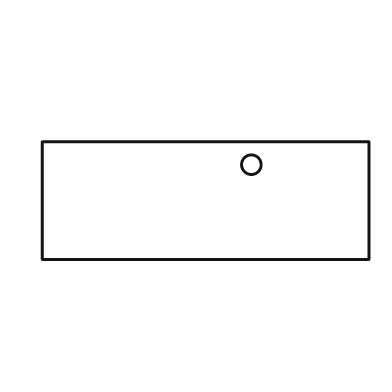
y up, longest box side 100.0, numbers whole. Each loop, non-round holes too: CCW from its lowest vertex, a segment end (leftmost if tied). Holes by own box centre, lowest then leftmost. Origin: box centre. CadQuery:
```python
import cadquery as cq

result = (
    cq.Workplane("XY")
    .moveTo(-50.0, -18.0)
    .lineTo(50.0, -18.0)
    .lineTo(50.0, 18.0)
    .lineTo(-50.0, 18.0)
    .close()
    .moveTo(14.0, 11.0)
    .circle(3.0)
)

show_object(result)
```